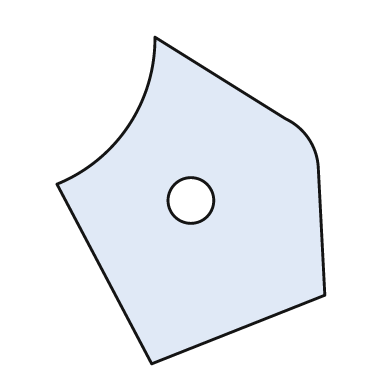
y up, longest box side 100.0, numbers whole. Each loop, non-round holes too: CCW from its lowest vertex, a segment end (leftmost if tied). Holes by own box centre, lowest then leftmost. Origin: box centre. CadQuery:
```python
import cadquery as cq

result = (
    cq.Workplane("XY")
    .moveTo(-12.0, -50.0)
    .lineTo(41.0, -29.0)
    .lineTo(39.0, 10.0)
    .threePointArc((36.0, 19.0), (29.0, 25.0))
    .lineTo(-11.0, 50.0)
    .threePointArc((-19.0, 23.0), (-41.0, 5.0))
    .close()
    .moveTo(0.0, 0.0)
    .circle(7.0)
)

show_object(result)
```